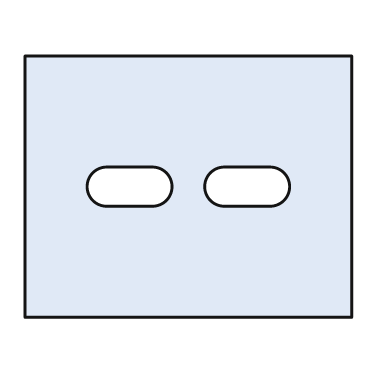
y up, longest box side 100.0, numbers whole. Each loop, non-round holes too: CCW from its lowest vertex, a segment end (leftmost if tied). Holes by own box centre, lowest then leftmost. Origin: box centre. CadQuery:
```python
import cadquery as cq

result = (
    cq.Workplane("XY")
    .moveTo(-50.0, -40.0)
    .lineTo(50.0, -40.0)
    .lineTo(50.0, 40.0)
    .lineTo(-50.0, 40.0)
    .close()
    .moveTo(-25.0, -6.0)
    .lineTo(-11.0, -6.0)
    .threePointArc((-5.0, 0.0), (-11.0, 6.0))
    .lineTo(-25.0, 6.0)
    .threePointArc((-31.0, 0.0), (-25.0, -6.0))
    .close()
    .moveTo(11.0, -6.0)
    .lineTo(25.0, -6.0)
    .threePointArc((31.0, 0.0), (25.0, 6.0))
    .lineTo(11.0, 6.0)
    .threePointArc((5.0, 0.0), (11.0, -6.0))
    .close()
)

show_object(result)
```